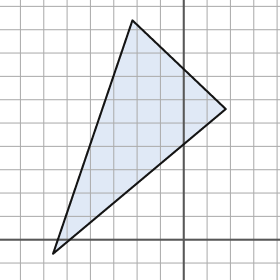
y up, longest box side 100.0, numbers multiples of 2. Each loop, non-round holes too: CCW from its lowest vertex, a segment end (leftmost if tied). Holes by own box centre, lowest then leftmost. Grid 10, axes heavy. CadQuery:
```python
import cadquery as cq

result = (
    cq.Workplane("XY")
    .moveTo(-56.0, -6.0)
    .lineTo(18.0, 56.0)
    .lineTo(-22.0, 94.0)
    .close()
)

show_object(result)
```